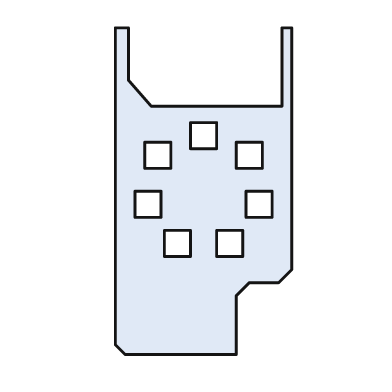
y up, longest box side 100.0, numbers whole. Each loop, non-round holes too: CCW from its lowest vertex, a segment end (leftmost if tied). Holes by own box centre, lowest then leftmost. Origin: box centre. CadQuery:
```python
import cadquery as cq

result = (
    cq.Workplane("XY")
    .moveTo(-24.0, -50.0)
    .lineTo(10.0, -50.0)
    .lineTo(10.0, -32.0)
    .lineTo(14.0, -28.0)
    .lineTo(23.0, -28.0)
    .lineTo(27.0, -24.0)
    .lineTo(27.0, 50.0)
    .lineTo(24.0, 50.0)
    .lineTo(24.0, 26.0)
    .lineTo(-16.0, 26.0)
    .lineTo(-23.0, 34.0)
    .lineTo(-23.0, 50.0)
    .lineTo(-27.0, 50.0)
    .lineTo(-27.0, -47.0)
    .close()
    .moveTo(-12.0, -20.0)
    .lineTo(-4.0, -20.0)
    .lineTo(-4.0, -12.0)
    .lineTo(-12.0, -12.0)
    .close()
    .moveTo(4.0, -20.0)
    .lineTo(12.0, -20.0)
    .lineTo(12.0, -12.0)
    .lineTo(4.0, -12.0)
    .close()
    .moveTo(-21.0, -8.0)
    .lineTo(-13.0, -8.0)
    .lineTo(-13.0, 0.0)
    .lineTo(-21.0, 0.0)
    .close()
    .moveTo(13.0, -8.0)
    .lineTo(21.0, -8.0)
    .lineTo(21.0, 0.0)
    .lineTo(13.0, 0.0)
    .close()
    .moveTo(-18.0, 7.0)
    .lineTo(-10.0, 7.0)
    .lineTo(-10.0, 15.0)
    .lineTo(-18.0, 15.0)
    .close()
    .moveTo(10.0, 7.0)
    .lineTo(18.0, 7.0)
    .lineTo(18.0, 15.0)
    .lineTo(10.0, 15.0)
    .close()
    .moveTo(-4.0, 13.0)
    .lineTo(4.0, 13.0)
    .lineTo(4.0, 21.0)
    .lineTo(-4.0, 21.0)
    .close()
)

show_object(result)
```